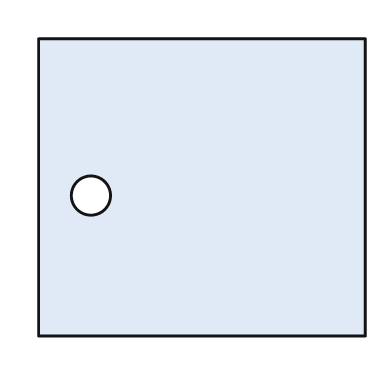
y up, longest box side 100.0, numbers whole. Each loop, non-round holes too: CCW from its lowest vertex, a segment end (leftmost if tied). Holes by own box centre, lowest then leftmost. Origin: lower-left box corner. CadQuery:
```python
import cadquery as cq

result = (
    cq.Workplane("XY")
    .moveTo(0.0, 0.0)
    .lineTo(100.0, 0.0)
    .lineTo(100.0, 91.0)
    .lineTo(0.0, 91.0)
    .close()
    .moveTo(16.0, 43.0)
    .circle(6.0)
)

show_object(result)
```